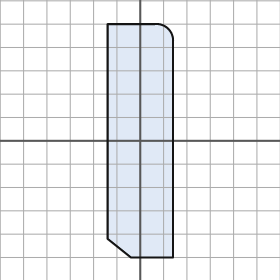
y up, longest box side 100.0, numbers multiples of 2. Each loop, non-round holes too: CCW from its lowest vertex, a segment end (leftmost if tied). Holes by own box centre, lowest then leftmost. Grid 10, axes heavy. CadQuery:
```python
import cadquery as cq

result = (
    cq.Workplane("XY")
    .moveTo(-4.0, -50.0)
    .lineTo(14.0, -50.0)
    .lineTo(14.0, 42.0)
    .threePointArc((12.0, 48.0), (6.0, 50.0))
    .lineTo(-14.0, 50.0)
    .lineTo(-14.0, -42.0)
    .close()
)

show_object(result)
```